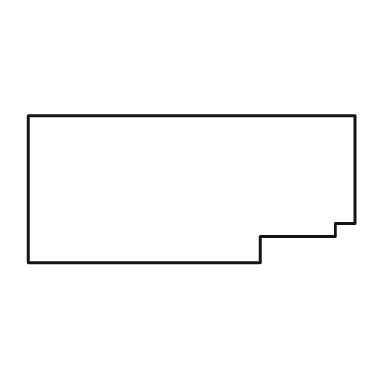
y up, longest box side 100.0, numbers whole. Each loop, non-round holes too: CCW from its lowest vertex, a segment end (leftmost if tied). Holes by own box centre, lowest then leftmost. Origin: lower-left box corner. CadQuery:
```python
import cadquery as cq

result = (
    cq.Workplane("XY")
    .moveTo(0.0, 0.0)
    .lineTo(71.0, 0.0)
    .lineTo(71.0, 8.0)
    .lineTo(94.0, 8.0)
    .lineTo(94.0, 12.0)
    .lineTo(100.0, 12.0)
    .lineTo(100.0, 45.0)
    .lineTo(0.0, 45.0)
    .close()
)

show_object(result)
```